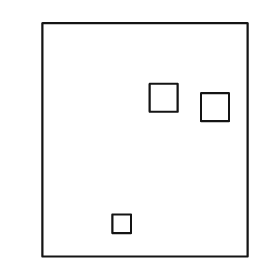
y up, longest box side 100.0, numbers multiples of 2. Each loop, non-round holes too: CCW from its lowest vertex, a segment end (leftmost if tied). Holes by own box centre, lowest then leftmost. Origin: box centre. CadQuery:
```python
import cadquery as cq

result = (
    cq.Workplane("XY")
    .moveTo(-44.0, -50.0)
    .lineTo(44.0, -50.0)
    .lineTo(44.0, 50.0)
    .lineTo(-44.0, 50.0)
    .close()
    .moveTo(-14.0, -40.0)
    .lineTo(-6.0, -40.0)
    .lineTo(-6.0, -32.0)
    .lineTo(-14.0, -32.0)
    .close()
    .moveTo(24.0, 8.0)
    .lineTo(36.0, 8.0)
    .lineTo(36.0, 20.0)
    .lineTo(24.0, 20.0)
    .close()
    .moveTo(2.0, 12.0)
    .lineTo(14.0, 12.0)
    .lineTo(14.0, 24.0)
    .lineTo(2.0, 24.0)
    .close()
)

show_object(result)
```